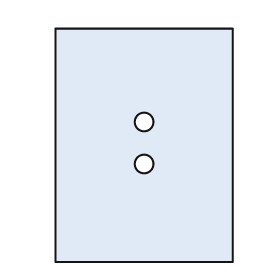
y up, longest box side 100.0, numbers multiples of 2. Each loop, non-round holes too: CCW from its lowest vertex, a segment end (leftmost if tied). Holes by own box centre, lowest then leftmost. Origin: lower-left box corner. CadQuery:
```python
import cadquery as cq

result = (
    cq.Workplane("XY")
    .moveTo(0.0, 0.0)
    .lineTo(76.0, 0.0)
    .lineTo(76.0, 100.0)
    .lineTo(0.0, 100.0)
    .close()
    .moveTo(38.0, 42.0)
    .circle(4.0)
    .moveTo(38.0, 60.0)
    .circle(4.0)
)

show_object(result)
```